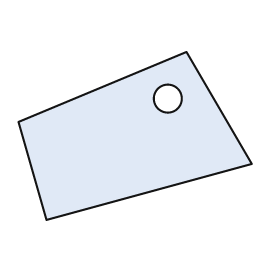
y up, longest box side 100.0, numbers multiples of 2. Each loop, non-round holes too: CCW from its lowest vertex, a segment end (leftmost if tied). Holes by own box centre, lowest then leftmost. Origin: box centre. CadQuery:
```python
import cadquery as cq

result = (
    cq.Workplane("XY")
    .moveTo(-38.0, -36.0)
    .lineTo(50.0, -12.0)
    .lineTo(22.0, 36.0)
    .lineTo(-50.0, 6.0)
    .close()
    .moveTo(14.0, 16.0)
    .circle(6.0)
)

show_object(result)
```